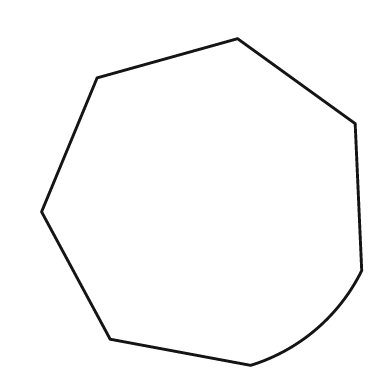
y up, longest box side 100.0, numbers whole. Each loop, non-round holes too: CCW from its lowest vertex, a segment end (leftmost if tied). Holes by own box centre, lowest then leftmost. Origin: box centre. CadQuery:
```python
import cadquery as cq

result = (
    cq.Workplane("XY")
    .moveTo(15.0, -50.0)
    .threePointArc((35.0, -39.0), (49.0, -21.0))
    .lineTo(47.0, 24.0)
    .lineTo(11.0, 50.0)
    .lineTo(-32.0, 38.0)
    .lineTo(-49.0, -3.0)
    .lineTo(-28.0, -42.0)
    .close()
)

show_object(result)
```